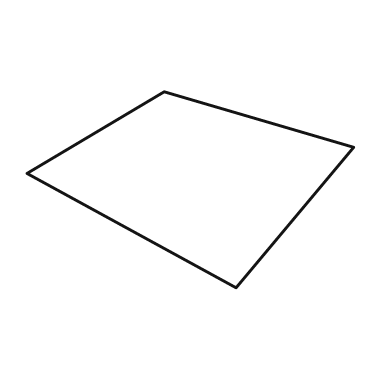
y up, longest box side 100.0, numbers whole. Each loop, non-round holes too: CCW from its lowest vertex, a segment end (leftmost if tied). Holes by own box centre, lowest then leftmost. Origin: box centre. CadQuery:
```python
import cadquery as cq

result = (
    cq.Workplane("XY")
    .moveTo(14.0, -30.0)
    .lineTo(50.0, 13.0)
    .lineTo(-8.0, 30.0)
    .lineTo(-50.0, 5.0)
    .close()
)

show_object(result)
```